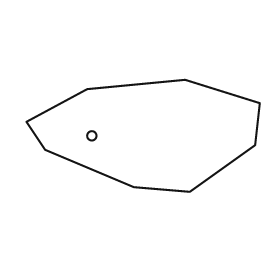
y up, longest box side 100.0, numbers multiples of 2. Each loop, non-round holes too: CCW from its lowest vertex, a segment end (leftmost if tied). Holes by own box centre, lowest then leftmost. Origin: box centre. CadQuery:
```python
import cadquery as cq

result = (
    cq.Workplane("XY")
    .moveTo(20.0, -24.0)
    .lineTo(48.0, -4.0)
    .lineTo(50.0, 14.0)
    .lineTo(18.0, 24.0)
    .lineTo(-24.0, 20.0)
    .lineTo(-50.0, 6.0)
    .lineTo(-42.0, -6.0)
    .lineTo(-4.0, -22.0)
    .close()
    .moveTo(-22.0, 0.0)
    .circle(2.0)
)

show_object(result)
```